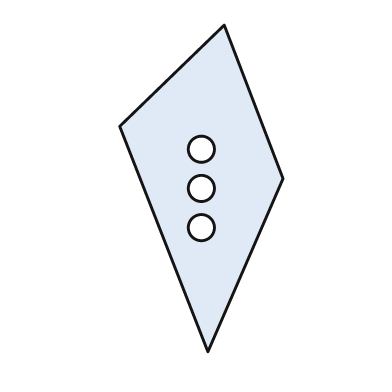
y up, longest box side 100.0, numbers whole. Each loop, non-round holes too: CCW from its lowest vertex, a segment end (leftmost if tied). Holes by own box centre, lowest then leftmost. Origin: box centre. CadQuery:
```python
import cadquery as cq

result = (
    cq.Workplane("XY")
    .moveTo(2.0, -50.0)
    .lineTo(25.0, 3.0)
    .lineTo(7.0, 50.0)
    .lineTo(-25.0, 19.0)
    .close()
    .moveTo(0.0, -12.0)
    .circle(4.0)
    .moveTo(0.0, 0.0)
    .circle(4.0)
    .moveTo(0.0, 12.0)
    .circle(4.0)
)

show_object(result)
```